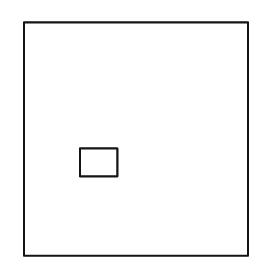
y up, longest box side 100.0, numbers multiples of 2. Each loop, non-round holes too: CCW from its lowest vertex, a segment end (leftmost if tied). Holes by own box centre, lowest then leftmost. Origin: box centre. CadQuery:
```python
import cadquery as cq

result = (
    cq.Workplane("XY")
    .moveTo(-48.0, -50.0)
    .lineTo(48.0, -50.0)
    .lineTo(48.0, 50.0)
    .lineTo(-48.0, 50.0)
    .close()
    .moveTo(-24.0, -16.0)
    .lineTo(-8.0, -16.0)
    .lineTo(-8.0, -4.0)
    .lineTo(-24.0, -4.0)
    .close()
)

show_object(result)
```